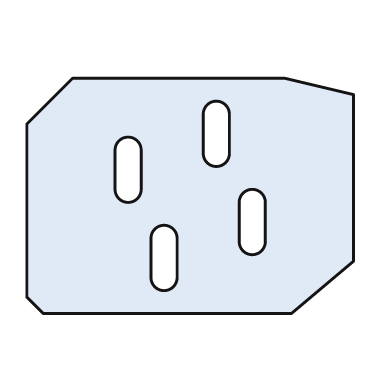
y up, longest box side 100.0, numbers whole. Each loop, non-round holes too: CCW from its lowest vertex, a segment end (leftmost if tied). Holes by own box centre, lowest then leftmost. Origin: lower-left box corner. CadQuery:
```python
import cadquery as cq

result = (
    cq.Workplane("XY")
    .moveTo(5.0, 0.0)
    .lineTo(81.0, 0.0)
    .lineTo(100.0, 16.0)
    .lineTo(100.0, 67.0)
    .lineTo(79.0, 72.0)
    .lineTo(14.0, 72.0)
    .lineTo(0.0, 58.0)
    .lineTo(0.0, 5.0)
    .close()
    .moveTo(38.0, 11.0)
    .threePointArc((42.0, 7.0), (46.0, 11.0))
    .lineTo(46.0, 23.0)
    .threePointArc((42.0, 27.0), (38.0, 23.0))
    .close()
    .moveTo(65.0, 22.0)
    .threePointArc((69.0, 18.0), (73.0, 22.0))
    .lineTo(73.0, 34.0)
    .threePointArc((69.0, 38.0), (65.0, 34.0))
    .close()
    .moveTo(27.0, 38.0)
    .threePointArc((31.0, 34.0), (35.0, 38.0))
    .lineTo(35.0, 50.0)
    .threePointArc((31.0, 54.0), (27.0, 50.0))
    .close()
    .moveTo(54.0, 49.0)
    .threePointArc((58.0, 45.0), (62.0, 49.0))
    .lineTo(62.0, 61.0)
    .threePointArc((58.0, 65.0), (54.0, 61.0))
    .close()
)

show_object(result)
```